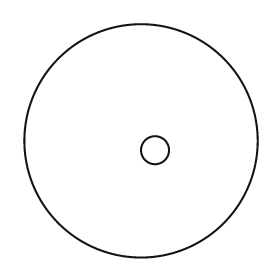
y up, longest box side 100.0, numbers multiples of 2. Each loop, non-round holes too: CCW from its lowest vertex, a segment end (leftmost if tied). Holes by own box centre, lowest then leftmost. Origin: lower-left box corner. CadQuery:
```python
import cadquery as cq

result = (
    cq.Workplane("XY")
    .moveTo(50.0, 50.0)
    .circle(50.0)
    .moveTo(56.0, 46.0)
    .circle(6.0)
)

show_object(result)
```